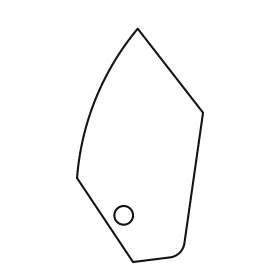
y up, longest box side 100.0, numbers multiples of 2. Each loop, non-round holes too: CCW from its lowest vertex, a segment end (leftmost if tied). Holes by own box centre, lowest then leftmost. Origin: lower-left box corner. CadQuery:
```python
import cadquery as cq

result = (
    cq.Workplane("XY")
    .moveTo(24.0, 0.0)
    .lineTo(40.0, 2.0)
    .threePointArc((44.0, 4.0), (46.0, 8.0))
    .lineTo(54.0, 64.0)
    .lineTo(26.0, 100.0)
    .threePointArc((8.0, 70.0), (0.0, 36.0))
    .close()
    .moveTo(20.0, 20.0)
    .circle(4.0)
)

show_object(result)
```